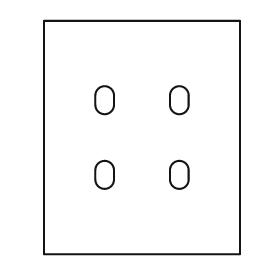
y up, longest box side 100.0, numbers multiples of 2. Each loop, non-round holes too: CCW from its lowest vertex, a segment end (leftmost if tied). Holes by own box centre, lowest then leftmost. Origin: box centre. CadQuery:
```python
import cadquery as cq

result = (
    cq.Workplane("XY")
    .moveTo(-42.0, -50.0)
    .lineTo(42.0, -50.0)
    .lineTo(42.0, 50.0)
    .lineTo(-42.0, 50.0)
    .close()
    .moveTo(-20.0, -18.0)
    .threePointArc((-16.0, -22.0), (-12.0, -18.0))
    .lineTo(-12.0, -14.0)
    .threePointArc((-16.0, -10.0), (-20.0, -14.0))
    .close()
    .moveTo(12.0, -18.0)
    .threePointArc((16.0, -22.0), (20.0, -18.0))
    .lineTo(20.0, -14.0)
    .threePointArc((16.0, -10.0), (12.0, -14.0))
    .close()
    .moveTo(-20.0, 14.0)
    .threePointArc((-16.0, 10.0), (-12.0, 14.0))
    .lineTo(-12.0, 18.0)
    .threePointArc((-16.0, 22.0), (-20.0, 18.0))
    .close()
    .moveTo(12.0, 14.0)
    .threePointArc((16.0, 10.0), (20.0, 14.0))
    .lineTo(20.0, 18.0)
    .threePointArc((16.0, 22.0), (12.0, 18.0))
    .close()
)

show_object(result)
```